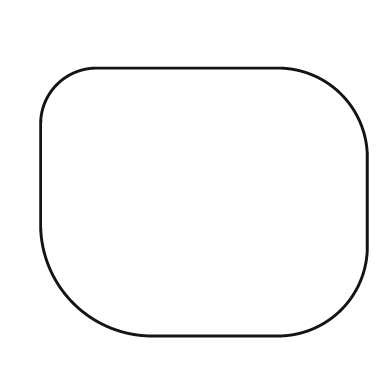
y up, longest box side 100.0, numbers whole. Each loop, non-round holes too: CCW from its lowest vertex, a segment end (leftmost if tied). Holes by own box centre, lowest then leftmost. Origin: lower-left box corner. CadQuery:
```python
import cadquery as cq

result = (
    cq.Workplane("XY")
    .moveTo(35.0, 0.0)
    .lineTo(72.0, 0.0)
    .threePointArc((92.0, 8.0), (100.0, 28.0))
    .lineTo(100.0, 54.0)
    .threePointArc((92.0, 74.0), (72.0, 82.0))
    .lineTo(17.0, 82.0)
    .threePointArc((5.0, 77.0), (0.0, 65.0))
    .lineTo(0.0, 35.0)
    .threePointArc((10.0, 10.0), (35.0, 0.0))
    .close()
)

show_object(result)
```